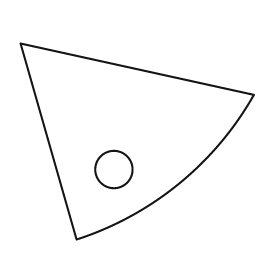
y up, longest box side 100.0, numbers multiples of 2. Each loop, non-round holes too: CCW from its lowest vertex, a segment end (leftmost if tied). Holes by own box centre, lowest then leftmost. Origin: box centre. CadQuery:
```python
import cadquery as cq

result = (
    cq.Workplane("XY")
    .moveTo(-26.0, -42.0)
    .threePointArc((18.0, -18.0), (50.0, 20.0))
    .lineTo(-50.0, 42.0)
    .close()
    .moveTo(-10.0, -12.0)
    .circle(8.0)
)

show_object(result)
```